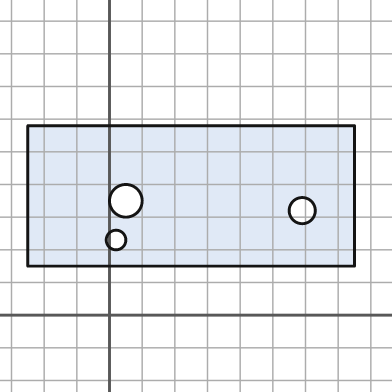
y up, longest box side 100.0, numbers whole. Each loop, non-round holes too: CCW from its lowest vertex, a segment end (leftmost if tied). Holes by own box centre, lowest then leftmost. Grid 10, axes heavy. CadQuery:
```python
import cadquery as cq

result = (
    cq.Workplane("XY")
    .moveTo(-25.0, 15.0)
    .lineTo(75.0, 15.0)
    .lineTo(75.0, 58.0)
    .lineTo(-25.0, 58.0)
    .close()
    .moveTo(2.0, 23.0)
    .circle(3.0)
    .moveTo(59.0, 32.0)
    .circle(4.0)
    .moveTo(5.0, 35.0)
    .circle(5.0)
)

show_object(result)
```